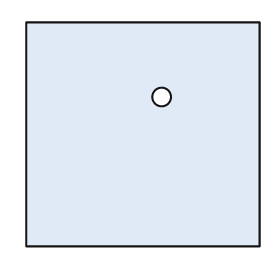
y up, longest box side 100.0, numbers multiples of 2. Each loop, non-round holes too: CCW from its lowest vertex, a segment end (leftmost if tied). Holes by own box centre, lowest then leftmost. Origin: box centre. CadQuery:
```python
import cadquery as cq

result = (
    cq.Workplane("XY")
    .moveTo(-50.0, -48.0)
    .lineTo(50.0, -48.0)
    .lineTo(50.0, 48.0)
    .lineTo(-50.0, 48.0)
    .close()
    .moveTo(8.0, 16.0)
    .circle(4.0)
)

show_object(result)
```